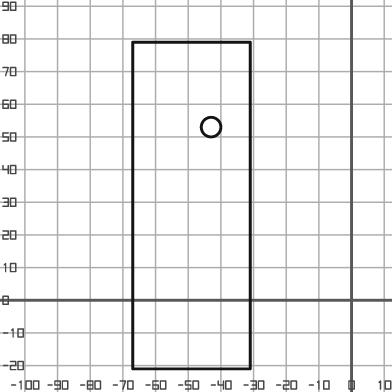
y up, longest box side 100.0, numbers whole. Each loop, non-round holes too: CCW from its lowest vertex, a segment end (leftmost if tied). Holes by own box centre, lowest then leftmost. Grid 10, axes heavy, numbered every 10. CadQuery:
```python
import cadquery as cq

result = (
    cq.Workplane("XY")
    .moveTo(-67.0, -21.0)
    .lineTo(-31.0, -21.0)
    .lineTo(-31.0, 79.0)
    .lineTo(-67.0, 79.0)
    .close()
    .moveTo(-43.0, 53.0)
    .circle(3.0)
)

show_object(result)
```